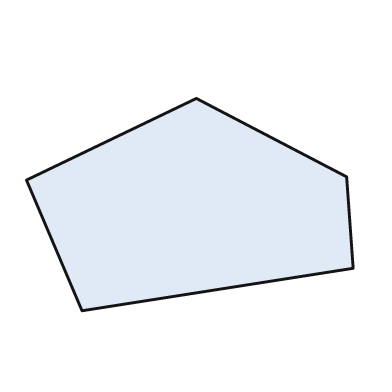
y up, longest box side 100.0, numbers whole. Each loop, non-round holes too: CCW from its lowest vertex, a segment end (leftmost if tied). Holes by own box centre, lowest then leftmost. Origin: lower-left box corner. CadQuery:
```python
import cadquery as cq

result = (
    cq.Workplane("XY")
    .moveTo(17.0, 0.0)
    .lineTo(100.0, 13.0)
    .lineTo(98.0, 41.0)
    .lineTo(52.0, 65.0)
    .lineTo(0.0, 40.0)
    .close()
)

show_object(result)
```